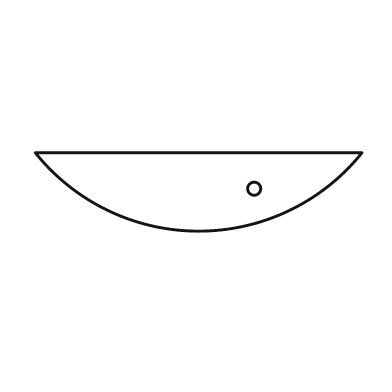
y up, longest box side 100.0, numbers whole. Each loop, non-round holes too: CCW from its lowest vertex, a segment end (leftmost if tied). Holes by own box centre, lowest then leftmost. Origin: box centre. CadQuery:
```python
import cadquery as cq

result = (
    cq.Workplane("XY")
    .moveTo(-50.0, 12.0)
    .threePointArc((0.0, -12.0), (50.0, 12.0))
    .close()
    .moveTo(17.0, 1.0)
    .circle(2.0)
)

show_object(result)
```